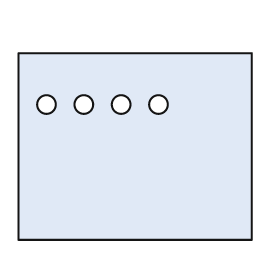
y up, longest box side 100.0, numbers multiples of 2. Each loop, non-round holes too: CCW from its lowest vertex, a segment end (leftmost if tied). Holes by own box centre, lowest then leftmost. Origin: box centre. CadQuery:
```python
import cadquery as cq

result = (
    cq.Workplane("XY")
    .moveTo(-50.0, -40.0)
    .lineTo(50.0, -40.0)
    .lineTo(50.0, 40.0)
    .lineTo(-50.0, 40.0)
    .close()
    .moveTo(-38.0, 18.0)
    .circle(4.0)
    .moveTo(-22.0, 18.0)
    .circle(4.0)
    .moveTo(-6.0, 18.0)
    .circle(4.0)
    .moveTo(10.0, 18.0)
    .circle(4.0)
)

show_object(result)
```